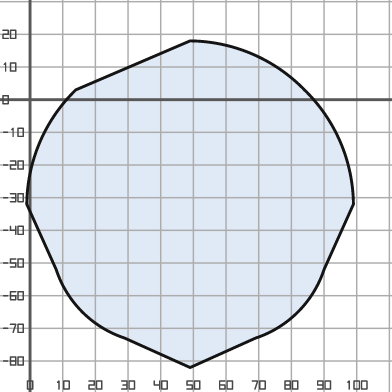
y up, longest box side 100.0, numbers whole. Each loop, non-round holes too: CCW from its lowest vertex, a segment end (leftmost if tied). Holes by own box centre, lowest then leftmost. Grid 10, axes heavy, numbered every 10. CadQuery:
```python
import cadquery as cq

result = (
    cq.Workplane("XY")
    .moveTo(49.0, -82.0)
    .lineTo(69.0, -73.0)
    .threePointArc((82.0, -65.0), (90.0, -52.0))
    .lineTo(99.0, -32.0)
    .threePointArc((95.0, -13.0), (84.0, 3.0))
    .threePointArc((68.0, 14.0), (49.0, 18.0))
    .lineTo(14.0, 3.0)
    .threePointArc((3.0, -13.0), (-1.0, -32.0))
    .lineTo(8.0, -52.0)
    .threePointArc((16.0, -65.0), (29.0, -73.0))
    .close()
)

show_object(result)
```